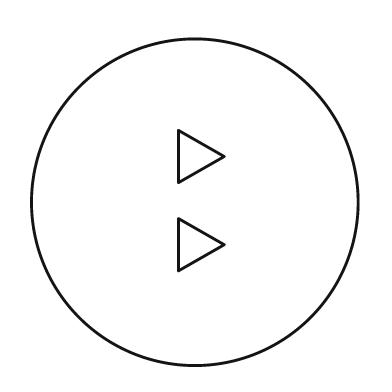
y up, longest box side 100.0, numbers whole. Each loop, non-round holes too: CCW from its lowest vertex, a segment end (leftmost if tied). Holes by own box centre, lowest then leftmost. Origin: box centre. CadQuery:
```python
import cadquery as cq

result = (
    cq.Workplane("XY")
    .moveTo(0.0, 0.0)
    .circle(50.0)
    .moveTo(-5.0, -21.0)
    .lineTo(9.0, -13.0)
    .lineTo(-5.0, -5.0)
    .close()
    .moveTo(-5.0, 6.0)
    .lineTo(9.0, 14.0)
    .lineTo(-5.0, 22.0)
    .close()
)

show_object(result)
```